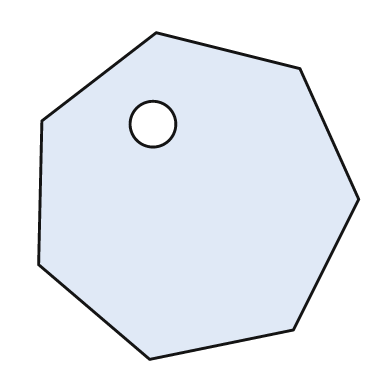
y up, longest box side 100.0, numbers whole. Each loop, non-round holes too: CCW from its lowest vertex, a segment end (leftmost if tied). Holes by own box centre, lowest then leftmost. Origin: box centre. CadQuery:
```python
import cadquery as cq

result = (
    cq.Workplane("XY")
    .moveTo(-15.0, -50.0)
    .lineTo(29.0, -41.0)
    .lineTo(49.0, -1.0)
    .lineTo(31.0, 39.0)
    .lineTo(-13.0, 50.0)
    .lineTo(-48.0, 23.0)
    .lineTo(-49.0, -21.0)
    .close()
    .moveTo(-14.0, 22.0)
    .circle(7.0)
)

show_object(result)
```